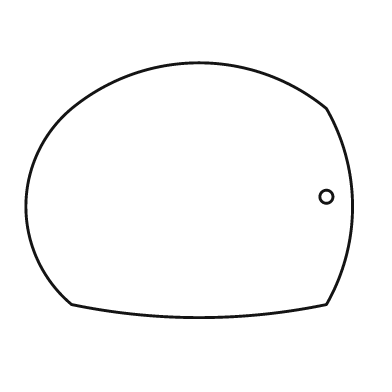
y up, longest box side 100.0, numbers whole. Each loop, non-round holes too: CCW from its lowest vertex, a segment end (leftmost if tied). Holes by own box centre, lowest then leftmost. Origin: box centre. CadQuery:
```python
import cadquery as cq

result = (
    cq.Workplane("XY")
    .moveTo(-36.0, -35.0)
    .threePointArc((3.0, -39.0), (42.0, -35.0))
    .threePointArc((50.0, -5.0), (42.0, 25.0))
    .threePointArc((3.0, 39.0), (-36.0, 25.0))
    .threePointArc((-50.0, -5.0), (-36.0, -35.0))
    .close()
    .moveTo(42.0, -2.0)
    .circle(2.0)
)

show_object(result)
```